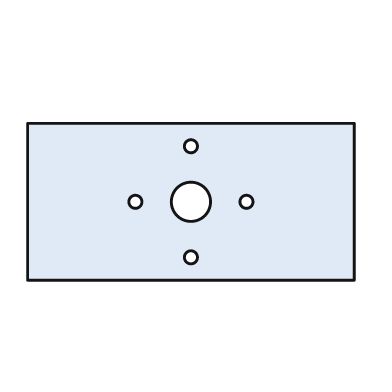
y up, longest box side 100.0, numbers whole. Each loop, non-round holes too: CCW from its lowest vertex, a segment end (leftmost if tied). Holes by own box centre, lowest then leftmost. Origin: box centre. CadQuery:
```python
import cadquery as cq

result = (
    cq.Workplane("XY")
    .moveTo(-50.0, -24.0)
    .lineTo(50.0, -24.0)
    .lineTo(50.0, 24.0)
    .lineTo(-50.0, 24.0)
    .close()
    .moveTo(0.0, -17.0)
    .circle(2.0)
    .moveTo(-17.0, 0.0)
    .circle(2.0)
    .moveTo(0.0, 0.0)
    .circle(6.0)
    .moveTo(17.0, 0.0)
    .circle(2.0)
    .moveTo(0.0, 17.0)
    .circle(2.0)
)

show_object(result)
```